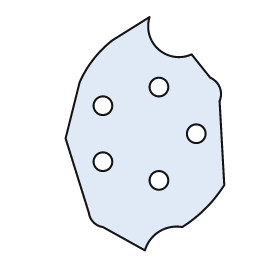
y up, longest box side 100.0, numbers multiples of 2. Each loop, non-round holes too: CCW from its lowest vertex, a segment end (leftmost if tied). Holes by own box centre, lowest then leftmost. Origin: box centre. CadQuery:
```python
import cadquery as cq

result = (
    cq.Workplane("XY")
    .moveTo(0.0, -50.0)
    .threePointArc((6.0, -42.0), (16.0, -40.0))
    .threePointArc((26.0, -32.0), (34.0, -22.0))
    .lineTo(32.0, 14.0)
    .threePointArc((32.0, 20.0), (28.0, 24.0))
    .lineTo(20.0, 34.0)
    .threePointArc((6.0, 36.0), (2.0, 50.0))
    .lineTo(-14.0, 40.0)
    .threePointArc((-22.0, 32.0), (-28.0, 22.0))
    .lineTo(-34.0, -2.0)
    .lineTo(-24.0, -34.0)
    .threePointArc((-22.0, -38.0), (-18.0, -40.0))
    .close()
    .moveTo(6.0, -20.0)
    .circle(4.0)
    .moveTo(-18.0, -12.0)
    .circle(4.0)
    .moveTo(22.0, 0.0)
    .circle(4.0)
    .moveTo(-18.0, 12.0)
    .circle(4.0)
    .moveTo(6.0, 20.0)
    .circle(4.0)
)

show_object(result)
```